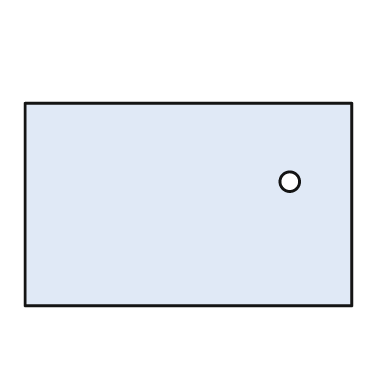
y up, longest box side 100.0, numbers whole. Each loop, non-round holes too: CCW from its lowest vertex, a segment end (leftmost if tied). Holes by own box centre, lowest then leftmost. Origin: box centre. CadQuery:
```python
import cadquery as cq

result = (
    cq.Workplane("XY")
    .moveTo(-50.0, -31.0)
    .lineTo(50.0, -31.0)
    .lineTo(50.0, 31.0)
    .lineTo(-50.0, 31.0)
    .close()
    .moveTo(31.0, 7.0)
    .circle(3.0)
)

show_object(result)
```